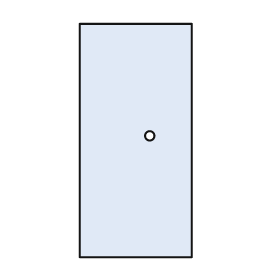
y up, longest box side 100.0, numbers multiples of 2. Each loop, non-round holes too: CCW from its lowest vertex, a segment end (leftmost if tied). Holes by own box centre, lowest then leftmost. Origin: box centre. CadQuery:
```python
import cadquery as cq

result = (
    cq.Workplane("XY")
    .moveTo(-24.0, -50.0)
    .lineTo(24.0, -50.0)
    .lineTo(24.0, 50.0)
    .lineTo(-24.0, 50.0)
    .close()
    .moveTo(6.0, 2.0)
    .circle(2.0)
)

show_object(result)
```